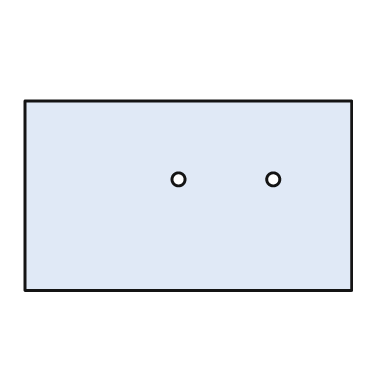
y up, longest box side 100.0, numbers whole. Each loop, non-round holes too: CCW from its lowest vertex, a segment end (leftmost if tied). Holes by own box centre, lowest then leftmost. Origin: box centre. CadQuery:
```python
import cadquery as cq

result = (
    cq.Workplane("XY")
    .moveTo(-50.0, -29.0)
    .lineTo(50.0, -29.0)
    .lineTo(50.0, 29.0)
    .lineTo(-50.0, 29.0)
    .close()
    .moveTo(-3.0, 5.0)
    .circle(2.0)
    .moveTo(26.0, 5.0)
    .circle(2.0)
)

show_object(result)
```